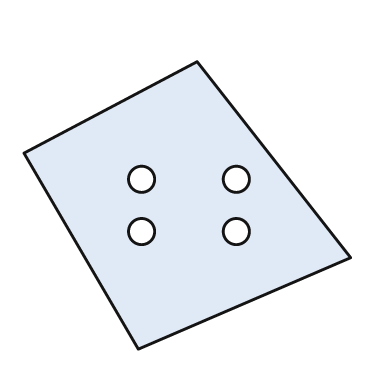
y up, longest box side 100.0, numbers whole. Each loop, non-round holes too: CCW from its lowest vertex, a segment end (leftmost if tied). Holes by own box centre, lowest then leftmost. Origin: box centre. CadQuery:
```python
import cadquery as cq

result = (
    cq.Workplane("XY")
    .moveTo(-15.0, -44.0)
    .lineTo(50.0, -16.0)
    .lineTo(3.0, 44.0)
    .lineTo(-50.0, 16.0)
    .close()
    .moveTo(-14.0, -8.0)
    .circle(4.0)
    .moveTo(15.0, -8.0)
    .circle(4.0)
    .moveTo(-14.0, 8.0)
    .circle(4.0)
    .moveTo(15.0, 8.0)
    .circle(4.0)
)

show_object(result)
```